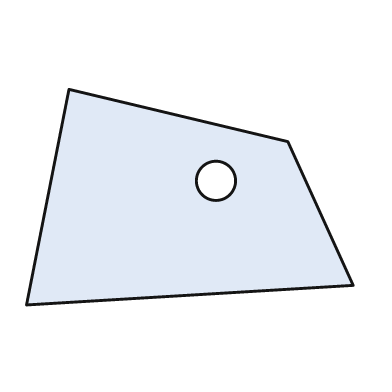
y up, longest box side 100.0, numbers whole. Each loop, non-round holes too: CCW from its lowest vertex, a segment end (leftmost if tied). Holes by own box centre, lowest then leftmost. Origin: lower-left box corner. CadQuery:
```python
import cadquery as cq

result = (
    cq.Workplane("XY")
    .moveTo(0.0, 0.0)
    .lineTo(100.0, 6.0)
    .lineTo(80.0, 50.0)
    .lineTo(13.0, 66.0)
    .close()
    .moveTo(58.0, 38.0)
    .circle(6.0)
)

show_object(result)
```